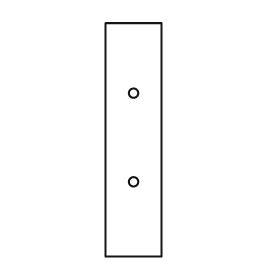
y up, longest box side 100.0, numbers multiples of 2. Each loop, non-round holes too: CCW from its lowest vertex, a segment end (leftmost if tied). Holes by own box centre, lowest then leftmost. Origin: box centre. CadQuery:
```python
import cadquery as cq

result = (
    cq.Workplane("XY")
    .moveTo(-12.0, -50.0)
    .lineTo(12.0, -50.0)
    .lineTo(12.0, 50.0)
    .lineTo(-12.0, 50.0)
    .close()
    .moveTo(0.0, -18.0)
    .circle(2.0)
    .moveTo(0.0, 20.0)
    .circle(2.0)
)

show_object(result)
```